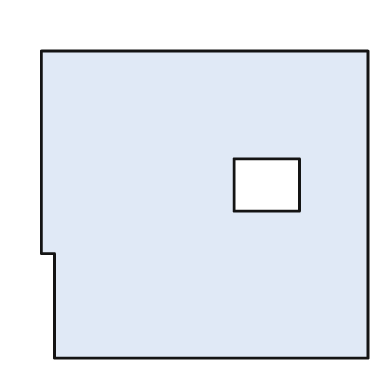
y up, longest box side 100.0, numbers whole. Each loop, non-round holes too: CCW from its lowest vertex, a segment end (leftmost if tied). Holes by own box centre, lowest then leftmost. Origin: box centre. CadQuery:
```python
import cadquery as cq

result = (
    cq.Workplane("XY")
    .moveTo(-46.0, -47.0)
    .lineTo(50.0, -47.0)
    .lineTo(50.0, 47.0)
    .lineTo(-50.0, 47.0)
    .lineTo(-50.0, -15.0)
    .lineTo(-46.0, -15.0)
    .close()
    .moveTo(9.0, -2.0)
    .lineTo(29.0, -2.0)
    .lineTo(29.0, 14.0)
    .lineTo(9.0, 14.0)
    .close()
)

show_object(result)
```